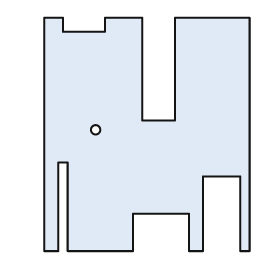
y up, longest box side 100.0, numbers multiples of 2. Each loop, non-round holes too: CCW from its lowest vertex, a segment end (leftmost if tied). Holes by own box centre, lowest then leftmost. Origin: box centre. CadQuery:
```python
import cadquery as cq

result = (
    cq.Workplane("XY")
    .moveTo(-44.0, -50.0)
    .lineTo(-38.0, -50.0)
    .lineTo(-38.0, -12.0)
    .lineTo(-34.0, -12.0)
    .lineTo(-34.0, -50.0)
    .lineTo(-6.0, -50.0)
    .lineTo(-6.0, -34.0)
    .lineTo(18.0, -34.0)
    .lineTo(18.0, -50.0)
    .lineTo(24.0, -50.0)
    .lineTo(24.0, -18.0)
    .lineTo(40.0, -18.0)
    .lineTo(40.0, -50.0)
    .lineTo(44.0, -50.0)
    .lineTo(44.0, 50.0)
    .lineTo(12.0, 50.0)
    .lineTo(12.0, 6.0)
    .lineTo(-2.0, 6.0)
    .lineTo(-2.0, 50.0)
    .lineTo(-18.0, 50.0)
    .lineTo(-18.0, 44.0)
    .lineTo(-36.0, 44.0)
    .lineTo(-36.0, 50.0)
    .lineTo(-44.0, 50.0)
    .close()
    .moveTo(-22.0, 2.0)
    .circle(2.0)
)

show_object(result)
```